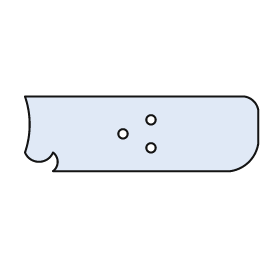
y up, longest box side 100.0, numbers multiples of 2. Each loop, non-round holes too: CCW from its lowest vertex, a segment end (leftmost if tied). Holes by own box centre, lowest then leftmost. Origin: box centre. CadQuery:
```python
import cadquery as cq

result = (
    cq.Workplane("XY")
    .moveTo(-38.0, -16.0)
    .lineTo(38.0, -16.0)
    .threePointArc((46.0, -12.0), (50.0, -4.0))
    .lineTo(50.0, 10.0)
    .threePointArc((48.0, 14.0), (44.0, 16.0))
    .lineTo(-50.0, 16.0)
    .threePointArc((-48.0, 4.0), (-50.0, -8.0))
    .threePointArc((-44.0, -12.0), (-38.0, -8.0))
    .threePointArc((-36.0, -12.0), (-38.0, -16.0))
    .close()
    .moveTo(4.0, -6.0)
    .circle(2.0)
    .moveTo(-8.0, 0.0)
    .circle(2.0)
    .moveTo(4.0, 6.0)
    .circle(2.0)
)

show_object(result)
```